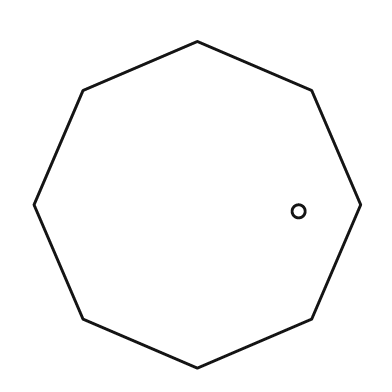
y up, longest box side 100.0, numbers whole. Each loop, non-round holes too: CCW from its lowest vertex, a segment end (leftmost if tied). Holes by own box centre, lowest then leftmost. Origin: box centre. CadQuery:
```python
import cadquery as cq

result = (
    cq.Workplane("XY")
    .moveTo(0.0, -50.0)
    .lineTo(35.0, -35.0)
    .lineTo(50.0, 0.0)
    .lineTo(35.0, 35.0)
    .lineTo(0.0, 50.0)
    .lineTo(-35.0, 35.0)
    .lineTo(-50.0, 0.0)
    .lineTo(-35.0, -35.0)
    .close()
    .moveTo(31.0, -2.0)
    .circle(2.0)
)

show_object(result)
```